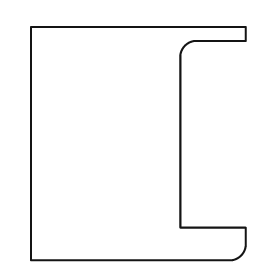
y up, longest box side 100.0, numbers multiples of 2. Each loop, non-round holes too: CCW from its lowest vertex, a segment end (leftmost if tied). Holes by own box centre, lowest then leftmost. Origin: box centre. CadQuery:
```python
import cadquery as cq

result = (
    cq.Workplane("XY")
    .moveTo(-46.0, -50.0)
    .lineTo(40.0, -50.0)
    .threePointArc((44.0, -48.0), (46.0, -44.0))
    .lineTo(46.0, -36.0)
    .lineTo(18.0, -36.0)
    .lineTo(18.0, 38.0)
    .threePointArc((20.0, 42.0), (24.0, 44.0))
    .lineTo(46.0, 44.0)
    .lineTo(46.0, 50.0)
    .lineTo(-46.0, 50.0)
    .close()
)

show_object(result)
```